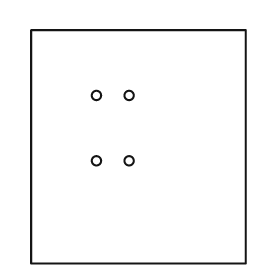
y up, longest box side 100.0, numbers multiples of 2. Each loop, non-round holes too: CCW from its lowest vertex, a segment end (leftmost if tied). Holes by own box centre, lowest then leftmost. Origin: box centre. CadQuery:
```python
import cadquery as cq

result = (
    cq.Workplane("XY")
    .moveTo(-46.0, -50.0)
    .lineTo(46.0, -50.0)
    .lineTo(46.0, 50.0)
    .lineTo(-46.0, 50.0)
    .close()
    .moveTo(-18.0, -6.0)
    .circle(2.0)
    .moveTo(-4.0, -6.0)
    .circle(2.0)
    .moveTo(-18.0, 22.0)
    .circle(2.0)
    .moveTo(-4.0, 22.0)
    .circle(2.0)
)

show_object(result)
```